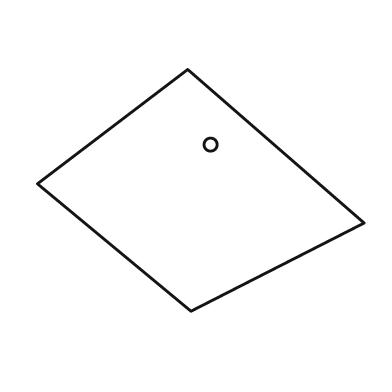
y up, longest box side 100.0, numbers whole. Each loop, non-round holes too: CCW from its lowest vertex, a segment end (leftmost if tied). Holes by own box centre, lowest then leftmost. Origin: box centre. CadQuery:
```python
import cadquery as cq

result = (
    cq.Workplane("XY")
    .moveTo(-3.0, -37.0)
    .lineTo(50.0, -10.0)
    .lineTo(-4.0, 37.0)
    .lineTo(-50.0, 2.0)
    .close()
    .moveTo(3.0, 14.0)
    .circle(2.0)
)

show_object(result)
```